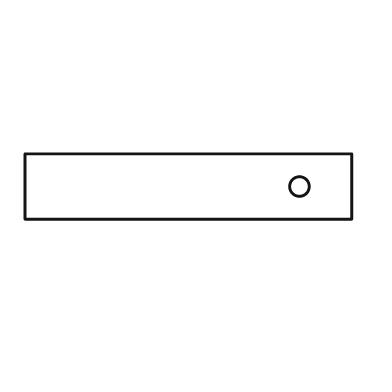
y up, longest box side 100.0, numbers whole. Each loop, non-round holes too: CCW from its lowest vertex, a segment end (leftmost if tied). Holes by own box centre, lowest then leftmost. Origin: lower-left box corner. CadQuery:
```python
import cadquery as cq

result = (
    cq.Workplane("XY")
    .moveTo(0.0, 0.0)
    .lineTo(100.0, 0.0)
    .lineTo(100.0, 20.0)
    .lineTo(0.0, 20.0)
    .close()
    .moveTo(84.0, 10.0)
    .circle(3.0)
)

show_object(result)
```